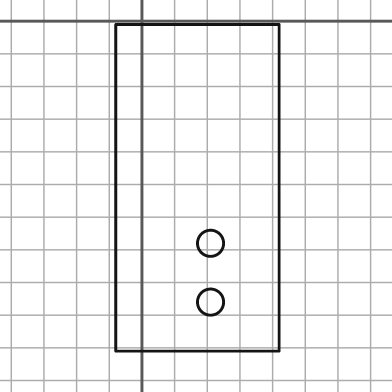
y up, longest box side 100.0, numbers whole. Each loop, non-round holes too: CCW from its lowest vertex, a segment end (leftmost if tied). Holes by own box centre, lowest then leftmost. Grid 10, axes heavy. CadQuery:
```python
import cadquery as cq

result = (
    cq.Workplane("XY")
    .moveTo(-8.0, -101.0)
    .lineTo(42.0, -101.0)
    .lineTo(42.0, -1.0)
    .lineTo(-8.0, -1.0)
    .close()
    .moveTo(21.0, -86.0)
    .circle(4.0)
    .moveTo(21.0, -68.0)
    .circle(4.0)
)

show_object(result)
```